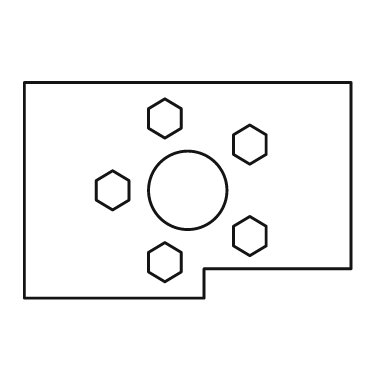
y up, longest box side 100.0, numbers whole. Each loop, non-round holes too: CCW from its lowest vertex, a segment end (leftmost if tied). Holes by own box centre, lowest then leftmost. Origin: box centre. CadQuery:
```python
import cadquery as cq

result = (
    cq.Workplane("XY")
    .moveTo(-50.0, -33.0)
    .lineTo(5.0, -33.0)
    .lineTo(5.0, -24.0)
    .lineTo(50.0, -24.0)
    .lineTo(50.0, 33.0)
    .lineTo(-50.0, 33.0)
    .close()
    .moveTo(-7.0, -28.0)
    .lineTo(-2.0, -25.0)
    .lineTo(-2.0, -19.0)
    .lineTo(-7.0, -16.0)
    .lineTo(-12.0, -19.0)
    .lineTo(-12.0, -25.0)
    .close()
    .moveTo(19.0, -20.0)
    .lineTo(24.0, -17.0)
    .lineTo(24.0, -11.0)
    .lineTo(19.0, -8.0)
    .lineTo(14.0, -11.0)
    .lineTo(14.0, -17.0)
    .close()
    .moveTo(-23.0, -6.0)
    .lineTo(-18.0, -3.0)
    .lineTo(-18.0, 3.0)
    .lineTo(-23.0, 6.0)
    .lineTo(-28.0, 3.0)
    .lineTo(-28.0, -3.0)
    .close()
    .moveTo(0.0, 0.0)
    .circle(12.0)
    .moveTo(19.0, 8.0)
    .lineTo(24.0, 11.0)
    .lineTo(24.0, 17.0)
    .lineTo(19.0, 20.0)
    .lineTo(14.0, 17.0)
    .lineTo(14.0, 11.0)
    .close()
    .moveTo(-7.0, 16.0)
    .lineTo(-2.0, 19.0)
    .lineTo(-2.0, 25.0)
    .lineTo(-7.0, 28.0)
    .lineTo(-12.0, 25.0)
    .lineTo(-12.0, 19.0)
    .close()
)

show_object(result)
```